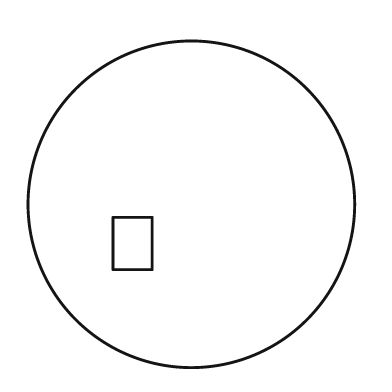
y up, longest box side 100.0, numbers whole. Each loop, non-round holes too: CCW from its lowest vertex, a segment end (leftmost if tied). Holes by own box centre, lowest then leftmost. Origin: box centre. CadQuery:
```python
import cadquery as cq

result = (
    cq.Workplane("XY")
    .moveTo(0.0, 0.0)
    .circle(50.0)
    .moveTo(-24.0, -20.0)
    .lineTo(-12.0, -20.0)
    .lineTo(-12.0, -4.0)
    .lineTo(-24.0, -4.0)
    .close()
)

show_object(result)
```